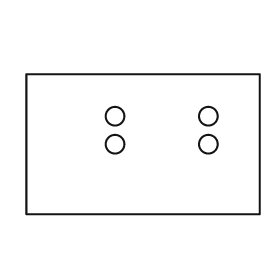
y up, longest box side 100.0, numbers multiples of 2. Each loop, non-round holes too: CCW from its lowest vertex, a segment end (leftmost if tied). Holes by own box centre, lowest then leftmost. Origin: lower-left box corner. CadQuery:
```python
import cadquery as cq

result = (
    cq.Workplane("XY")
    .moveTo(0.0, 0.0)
    .lineTo(100.0, 0.0)
    .lineTo(100.0, 60.0)
    .lineTo(0.0, 60.0)
    .close()
    .moveTo(38.0, 30.0)
    .circle(4.0)
    .moveTo(78.0, 30.0)
    .circle(4.0)
    .moveTo(38.0, 42.0)
    .circle(4.0)
    .moveTo(78.0, 42.0)
    .circle(4.0)
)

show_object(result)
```